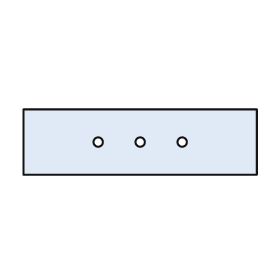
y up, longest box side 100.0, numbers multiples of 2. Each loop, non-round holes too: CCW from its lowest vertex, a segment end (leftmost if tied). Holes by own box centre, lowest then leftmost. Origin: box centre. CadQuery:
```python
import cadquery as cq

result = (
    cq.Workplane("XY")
    .moveTo(-50.0, -14.0)
    .lineTo(50.0, -14.0)
    .lineTo(50.0, 14.0)
    .lineTo(-50.0, 14.0)
    .close()
    .moveTo(-18.0, 0.0)
    .circle(2.0)
    .moveTo(0.0, 0.0)
    .circle(2.0)
    .moveTo(18.0, 0.0)
    .circle(2.0)
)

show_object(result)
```